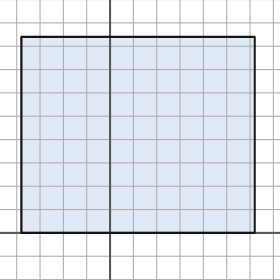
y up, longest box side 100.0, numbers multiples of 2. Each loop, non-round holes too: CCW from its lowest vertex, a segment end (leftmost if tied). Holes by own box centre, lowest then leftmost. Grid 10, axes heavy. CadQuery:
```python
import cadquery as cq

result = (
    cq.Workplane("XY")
    .moveTo(-38.0, 0.0)
    .lineTo(62.0, 0.0)
    .lineTo(62.0, 84.0)
    .lineTo(-38.0, 84.0)
    .close()
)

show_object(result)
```